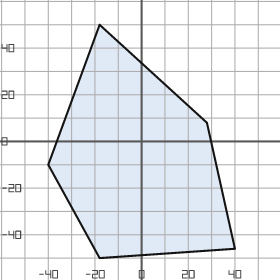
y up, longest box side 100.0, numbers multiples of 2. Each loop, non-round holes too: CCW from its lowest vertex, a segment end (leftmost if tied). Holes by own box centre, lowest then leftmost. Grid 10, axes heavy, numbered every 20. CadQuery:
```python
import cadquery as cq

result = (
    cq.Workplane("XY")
    .moveTo(-18.0, -50.0)
    .lineTo(40.0, -46.0)
    .lineTo(28.0, 8.0)
    .lineTo(-18.0, 50.0)
    .lineTo(-40.0, -10.0)
    .close()
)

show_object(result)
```